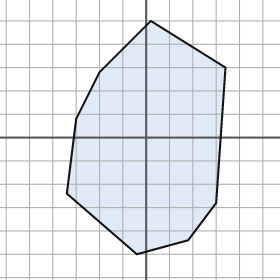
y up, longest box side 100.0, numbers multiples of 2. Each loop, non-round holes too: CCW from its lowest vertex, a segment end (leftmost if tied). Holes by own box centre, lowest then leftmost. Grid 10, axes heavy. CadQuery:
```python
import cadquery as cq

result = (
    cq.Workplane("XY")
    .moveTo(-4.0, -50.0)
    .lineTo(18.0, -44.0)
    .lineTo(30.0, -28.0)
    .lineTo(34.0, 30.0)
    .lineTo(2.0, 50.0)
    .lineTo(-20.0, 28.0)
    .lineTo(-30.0, 8.0)
    .lineTo(-34.0, -24.0)
    .close()
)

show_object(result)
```